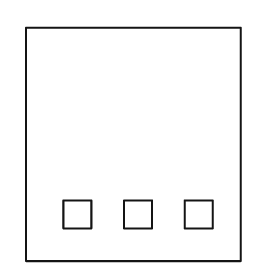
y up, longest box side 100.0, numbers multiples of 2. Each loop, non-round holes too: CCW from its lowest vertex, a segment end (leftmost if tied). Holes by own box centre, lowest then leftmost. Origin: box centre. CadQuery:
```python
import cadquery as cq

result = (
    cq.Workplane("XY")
    .moveTo(-46.0, -50.0)
    .lineTo(46.0, -50.0)
    .lineTo(46.0, 50.0)
    .lineTo(-46.0, 50.0)
    .close()
    .moveTo(-30.0, -36.0)
    .lineTo(-18.0, -36.0)
    .lineTo(-18.0, -24.0)
    .lineTo(-30.0, -24.0)
    .close()
    .moveTo(-4.0, -36.0)
    .lineTo(8.0, -36.0)
    .lineTo(8.0, -24.0)
    .lineTo(-4.0, -24.0)
    .close()
    .moveTo(22.0, -36.0)
    .lineTo(34.0, -36.0)
    .lineTo(34.0, -24.0)
    .lineTo(22.0, -24.0)
    .close()
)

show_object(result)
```